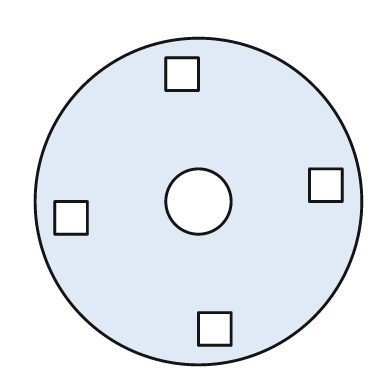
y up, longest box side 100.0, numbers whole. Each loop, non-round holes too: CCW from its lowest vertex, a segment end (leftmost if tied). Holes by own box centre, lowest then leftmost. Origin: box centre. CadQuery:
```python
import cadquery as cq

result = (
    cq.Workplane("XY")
    .moveTo(0.0, 0.0)
    .circle(50.0)
    .moveTo(0.0, -44.0)
    .lineTo(10.0, -44.0)
    .lineTo(10.0, -34.0)
    .lineTo(0.0, -34.0)
    .close()
    .moveTo(-44.0, -10.0)
    .lineTo(-34.0, -10.0)
    .lineTo(-34.0, 0.0)
    .lineTo(-44.0, 0.0)
    .close()
    .moveTo(0.0, 0.0)
    .circle(10.0)
    .moveTo(34.0, 0.0)
    .lineTo(44.0, 0.0)
    .lineTo(44.0, 10.0)
    .lineTo(34.0, 10.0)
    .close()
    .moveTo(-10.0, 34.0)
    .lineTo(0.0, 34.0)
    .lineTo(0.0, 44.0)
    .lineTo(-10.0, 44.0)
    .close()
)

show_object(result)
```